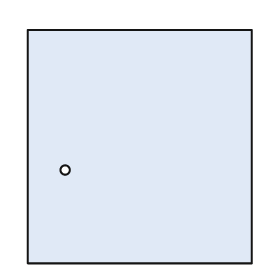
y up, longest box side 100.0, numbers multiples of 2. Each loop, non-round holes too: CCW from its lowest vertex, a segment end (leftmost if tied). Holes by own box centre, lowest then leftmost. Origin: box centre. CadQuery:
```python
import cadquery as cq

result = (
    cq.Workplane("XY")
    .moveTo(-48.0, -50.0)
    .lineTo(48.0, -50.0)
    .lineTo(48.0, 50.0)
    .lineTo(-48.0, 50.0)
    .close()
    .moveTo(-32.0, -10.0)
    .circle(2.0)
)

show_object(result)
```